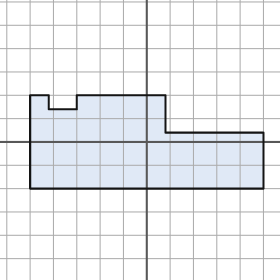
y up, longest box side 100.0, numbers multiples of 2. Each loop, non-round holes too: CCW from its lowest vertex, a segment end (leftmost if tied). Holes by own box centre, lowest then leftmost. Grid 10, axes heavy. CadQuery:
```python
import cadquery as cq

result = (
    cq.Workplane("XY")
    .moveTo(-50.0, -20.0)
    .lineTo(50.0, -20.0)
    .lineTo(50.0, 4.0)
    .lineTo(8.0, 4.0)
    .lineTo(8.0, 20.0)
    .lineTo(-30.0, 20.0)
    .lineTo(-30.0, 14.0)
    .lineTo(-42.0, 14.0)
    .lineTo(-42.0, 20.0)
    .lineTo(-50.0, 20.0)
    .close()
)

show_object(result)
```